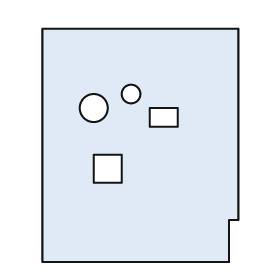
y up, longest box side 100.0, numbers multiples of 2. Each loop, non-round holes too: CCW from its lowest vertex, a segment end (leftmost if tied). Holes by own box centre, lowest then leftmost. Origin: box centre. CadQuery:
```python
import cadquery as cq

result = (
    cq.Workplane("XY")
    .moveTo(-42.0, -50.0)
    .lineTo(38.0, -50.0)
    .lineTo(38.0, -32.0)
    .lineTo(42.0, -32.0)
    .lineTo(42.0, 50.0)
    .lineTo(-42.0, 50.0)
    .close()
    .moveTo(-20.0, -16.0)
    .lineTo(-8.0, -16.0)
    .lineTo(-8.0, -4.0)
    .lineTo(-20.0, -4.0)
    .close()
    .moveTo(4.0, 8.0)
    .lineTo(16.0, 8.0)
    .lineTo(16.0, 16.0)
    .lineTo(4.0, 16.0)
    .close()
    .moveTo(-20.0, 16.0)
    .circle(6.0)
    .moveTo(-4.0, 22.0)
    .circle(4.0)
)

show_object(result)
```